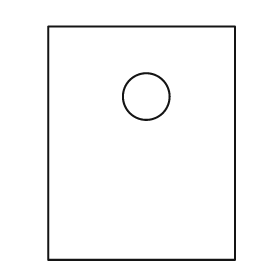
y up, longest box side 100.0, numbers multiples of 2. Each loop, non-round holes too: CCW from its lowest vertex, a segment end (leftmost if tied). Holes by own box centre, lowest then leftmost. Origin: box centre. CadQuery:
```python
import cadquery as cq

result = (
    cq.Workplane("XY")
    .moveTo(-40.0, -50.0)
    .lineTo(40.0, -50.0)
    .lineTo(40.0, 50.0)
    .lineTo(-40.0, 50.0)
    .close()
    .moveTo(2.0, 20.0)
    .circle(10.0)
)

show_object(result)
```